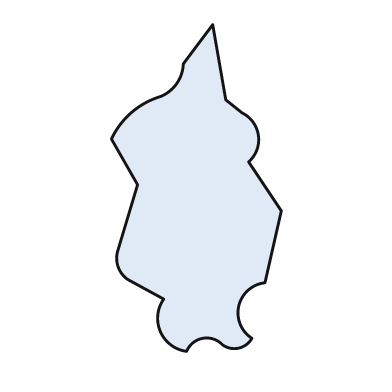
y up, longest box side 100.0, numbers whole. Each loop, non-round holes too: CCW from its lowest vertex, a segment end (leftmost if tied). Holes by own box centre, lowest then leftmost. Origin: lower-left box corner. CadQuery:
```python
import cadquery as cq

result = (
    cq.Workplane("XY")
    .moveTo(23.0, 0.0)
    .threePointArc((28.0, 4.0), (34.0, 2.0))
    .threePointArc((39.0, 1.0), (43.0, 4.0))
    .threePointArc((39.0, 14.0), (47.0, 21.0))
    .lineTo(52.0, 43.0)
    .lineTo(42.0, 58.0)
    .threePointArc((45.0, 66.0), (40.0, 73.0))
    .lineTo(35.0, 77.0)
    .lineTo(31.0, 100.0)
    .lineTo(22.0, 88.0)
    .threePointArc((20.0, 82.0), (15.0, 78.0))
    .threePointArc((6.0, 73.0), (0.0, 65.0))
    .lineTo(8.0, 51.0)
    .lineTo(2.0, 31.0)
    .threePointArc((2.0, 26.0), (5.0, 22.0))
    .lineTo(16.0, 16.0)
    .threePointArc((15.0, 6.0), (23.0, 0.0))
    .close()
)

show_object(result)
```